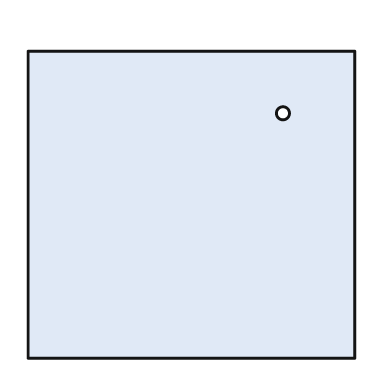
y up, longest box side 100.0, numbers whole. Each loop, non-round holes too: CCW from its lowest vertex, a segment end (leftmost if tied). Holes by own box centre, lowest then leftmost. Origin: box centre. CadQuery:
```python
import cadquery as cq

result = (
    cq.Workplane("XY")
    .moveTo(-50.0, -47.0)
    .lineTo(50.0, -47.0)
    .lineTo(50.0, 47.0)
    .lineTo(-50.0, 47.0)
    .close()
    .moveTo(28.0, 28.0)
    .circle(2.0)
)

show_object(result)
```